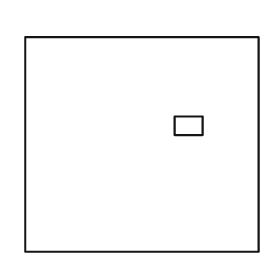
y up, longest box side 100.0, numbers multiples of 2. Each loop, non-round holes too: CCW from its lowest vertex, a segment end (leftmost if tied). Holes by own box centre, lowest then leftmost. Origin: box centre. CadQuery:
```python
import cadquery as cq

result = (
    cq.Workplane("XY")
    .moveTo(-50.0, -46.0)
    .lineTo(50.0, -46.0)
    .lineTo(50.0, 46.0)
    .lineTo(-50.0, 46.0)
    .close()
    .moveTo(14.0, 4.0)
    .lineTo(26.0, 4.0)
    .lineTo(26.0, 12.0)
    .lineTo(14.0, 12.0)
    .close()
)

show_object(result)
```